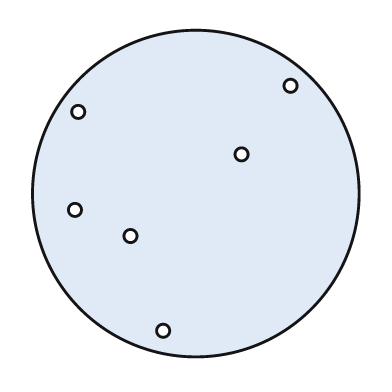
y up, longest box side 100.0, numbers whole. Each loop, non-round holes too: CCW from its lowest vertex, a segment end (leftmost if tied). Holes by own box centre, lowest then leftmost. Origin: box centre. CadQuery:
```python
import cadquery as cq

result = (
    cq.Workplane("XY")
    .moveTo(0.0, 0.0)
    .circle(50.0)
    .moveTo(-10.0, -42.0)
    .circle(2.0)
    .moveTo(-20.0, -13.0)
    .circle(2.0)
    .moveTo(-37.0, -5.0)
    .circle(2.0)
    .moveTo(14.0, 12.0)
    .circle(2.0)
    .moveTo(-36.0, 25.0)
    .circle(2.0)
    .moveTo(29.0, 33.0)
    .circle(2.0)
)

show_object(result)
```